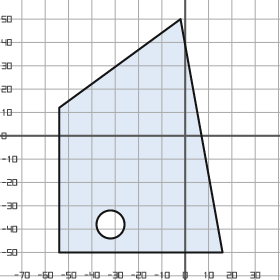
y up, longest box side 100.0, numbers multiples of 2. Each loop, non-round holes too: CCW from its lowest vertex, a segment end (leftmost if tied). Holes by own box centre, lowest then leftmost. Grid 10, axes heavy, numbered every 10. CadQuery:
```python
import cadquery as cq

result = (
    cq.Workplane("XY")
    .moveTo(-54.0, -50.0)
    .lineTo(16.0, -50.0)
    .lineTo(-2.0, 50.0)
    .lineTo(-54.0, 12.0)
    .close()
    .moveTo(-32.0, -38.0)
    .circle(6.0)
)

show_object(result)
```